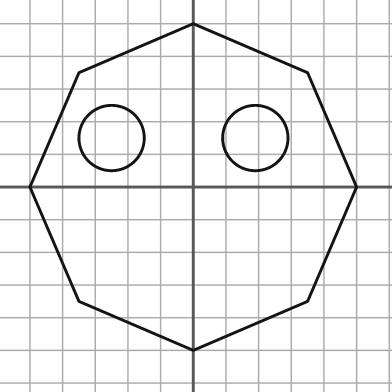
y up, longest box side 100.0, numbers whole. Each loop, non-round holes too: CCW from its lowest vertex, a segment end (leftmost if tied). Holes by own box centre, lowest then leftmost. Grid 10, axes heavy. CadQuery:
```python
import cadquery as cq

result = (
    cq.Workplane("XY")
    .moveTo(0.0, -50.0)
    .lineTo(35.0, -35.0)
    .lineTo(50.0, 0.0)
    .lineTo(35.0, 35.0)
    .lineTo(0.0, 50.0)
    .lineTo(-35.0, 35.0)
    .lineTo(-50.0, 0.0)
    .lineTo(-35.0, -35.0)
    .close()
    .moveTo(-25.0, 15.0)
    .circle(10.0)
    .moveTo(19.0, 15.0)
    .circle(10.0)
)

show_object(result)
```